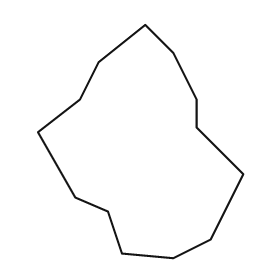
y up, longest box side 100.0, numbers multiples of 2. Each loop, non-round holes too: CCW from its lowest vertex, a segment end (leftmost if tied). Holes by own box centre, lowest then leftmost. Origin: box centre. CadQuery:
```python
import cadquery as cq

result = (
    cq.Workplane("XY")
    .moveTo(14.0, -50.0)
    .lineTo(30.0, -42.0)
    .lineTo(44.0, -14.0)
    .lineTo(24.0, 6.0)
    .lineTo(24.0, 18.0)
    .lineTo(14.0, 38.0)
    .lineTo(2.0, 50.0)
    .lineTo(-18.0, 34.0)
    .lineTo(-26.0, 18.0)
    .lineTo(-44.0, 4.0)
    .lineTo(-28.0, -24.0)
    .lineTo(-14.0, -30.0)
    .lineTo(-8.0, -48.0)
    .close()
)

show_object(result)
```